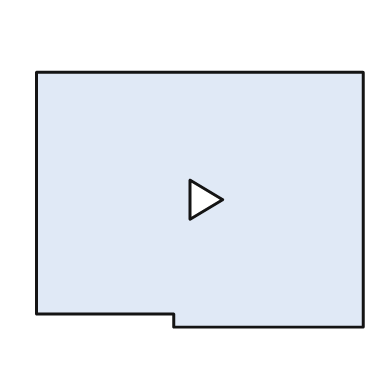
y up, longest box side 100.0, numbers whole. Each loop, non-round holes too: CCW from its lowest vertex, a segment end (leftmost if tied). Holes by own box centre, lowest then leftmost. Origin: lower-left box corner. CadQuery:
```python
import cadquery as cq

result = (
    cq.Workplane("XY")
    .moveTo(42.0, 0.0)
    .lineTo(100.0, 0.0)
    .lineTo(100.0, 78.0)
    .lineTo(0.0, 78.0)
    .lineTo(0.0, 4.0)
    .lineTo(42.0, 4.0)
    .close()
    .moveTo(47.0, 33.0)
    .lineTo(57.0, 39.0)
    .lineTo(47.0, 45.0)
    .close()
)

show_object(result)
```